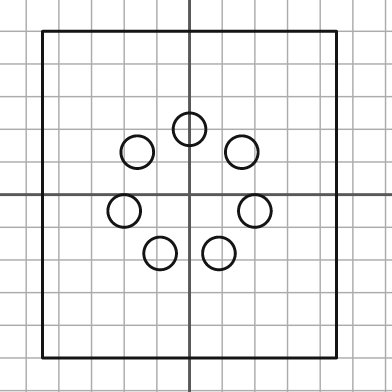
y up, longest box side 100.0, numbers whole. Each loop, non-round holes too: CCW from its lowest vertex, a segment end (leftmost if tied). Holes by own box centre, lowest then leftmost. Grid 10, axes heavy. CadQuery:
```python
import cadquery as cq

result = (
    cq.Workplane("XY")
    .moveTo(-45.0, -50.0)
    .lineTo(45.0, -50.0)
    .lineTo(45.0, 50.0)
    .lineTo(-45.0, 50.0)
    .close()
    .moveTo(-9.0, -18.0)
    .circle(5.0)
    .moveTo(9.0, -18.0)
    .circle(5.0)
    .moveTo(-20.0, -5.0)
    .circle(5.0)
    .moveTo(20.0, -5.0)
    .circle(5.0)
    .moveTo(-16.0, 13.0)
    .circle(5.0)
    .moveTo(16.0, 13.0)
    .circle(5.0)
    .moveTo(0.0, 20.0)
    .circle(5.0)
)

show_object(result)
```